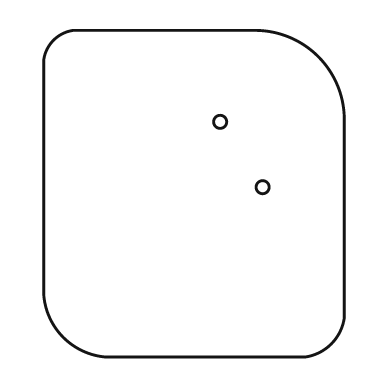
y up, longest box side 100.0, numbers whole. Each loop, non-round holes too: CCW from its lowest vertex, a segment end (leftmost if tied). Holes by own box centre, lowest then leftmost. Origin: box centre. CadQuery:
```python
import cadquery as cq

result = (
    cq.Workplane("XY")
    .moveTo(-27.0, -50.0)
    .lineTo(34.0, -50.0)
    .threePointArc((42.0, -46.0), (46.0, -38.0))
    .lineTo(46.0, 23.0)
    .threePointArc((38.0, 42.0), (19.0, 50.0))
    .lineTo(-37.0, 50.0)
    .threePointArc((-43.0, 47.0), (-46.0, 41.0))
    .lineTo(-46.0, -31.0)
    .threePointArc((-40.0, -44.0), (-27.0, -50.0))
    .close()
    .moveTo(21.0, 2.0)
    .circle(2.0)
    .moveTo(8.0, 22.0)
    .circle(2.0)
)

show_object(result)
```